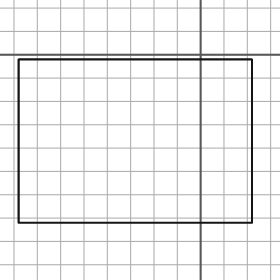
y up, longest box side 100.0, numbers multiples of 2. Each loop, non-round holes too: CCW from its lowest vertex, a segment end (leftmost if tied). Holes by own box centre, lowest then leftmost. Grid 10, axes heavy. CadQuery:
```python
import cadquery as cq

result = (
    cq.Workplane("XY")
    .moveTo(-78.0, -72.0)
    .lineTo(22.0, -72.0)
    .lineTo(22.0, -2.0)
    .lineTo(-78.0, -2.0)
    .close()
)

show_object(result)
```